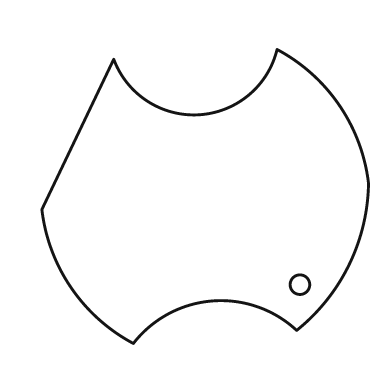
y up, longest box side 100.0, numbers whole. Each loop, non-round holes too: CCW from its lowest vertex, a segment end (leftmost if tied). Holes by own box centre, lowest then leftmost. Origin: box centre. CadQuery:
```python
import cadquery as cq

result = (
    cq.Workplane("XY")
    .moveTo(-22.0, -45.0)
    .threePointArc((2.0, -32.0), (28.0, -41.0))
    .threePointArc((44.0, -21.0), (50.0, 4.0))
    .threePointArc((41.0, 28.0), (22.0, 45.0))
    .threePointArc((-2.0, 25.0), (-28.0, 42.0))
    .lineTo(-50.0, -4.0)
    .threePointArc((-41.0, -28.0), (-22.0, -45.0))
    .close()
    .moveTo(29.0, -27.0)
    .circle(3.0)
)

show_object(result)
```